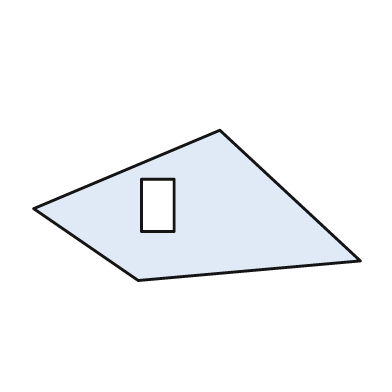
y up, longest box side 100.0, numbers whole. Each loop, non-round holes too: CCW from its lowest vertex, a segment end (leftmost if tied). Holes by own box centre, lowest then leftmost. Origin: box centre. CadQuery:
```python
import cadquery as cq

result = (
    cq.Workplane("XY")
    .moveTo(-18.0, -23.0)
    .lineTo(50.0, -17.0)
    .lineTo(7.0, 23.0)
    .lineTo(-50.0, -1.0)
    .close()
    .moveTo(-17.0, -8.0)
    .lineTo(-7.0, -8.0)
    .lineTo(-7.0, 8.0)
    .lineTo(-17.0, 8.0)
    .close()
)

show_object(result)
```